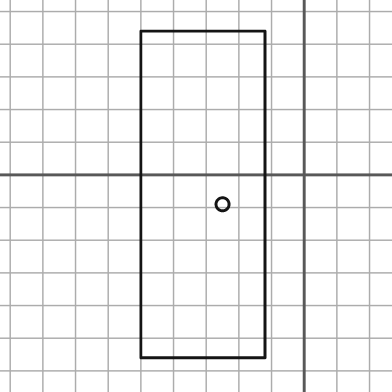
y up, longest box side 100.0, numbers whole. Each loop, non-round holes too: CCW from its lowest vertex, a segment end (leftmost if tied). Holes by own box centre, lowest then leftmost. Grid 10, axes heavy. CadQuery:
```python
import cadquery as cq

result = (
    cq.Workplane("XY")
    .moveTo(-50.0, -56.0)
    .lineTo(-12.0, -56.0)
    .lineTo(-12.0, 44.0)
    .lineTo(-50.0, 44.0)
    .close()
    .moveTo(-25.0, -9.0)
    .circle(2.0)
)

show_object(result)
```